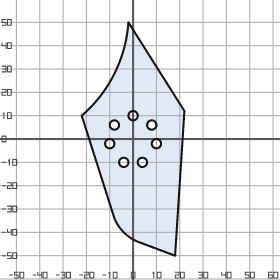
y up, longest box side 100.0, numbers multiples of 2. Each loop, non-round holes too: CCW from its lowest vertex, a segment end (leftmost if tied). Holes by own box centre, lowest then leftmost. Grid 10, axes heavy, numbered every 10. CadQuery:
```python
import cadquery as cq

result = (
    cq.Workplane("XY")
    .moveTo(18.0, -50.0)
    .lineTo(22.0, 12.0)
    .lineTo(-2.0, 50.0)
    .threePointArc((-8.0, 28.0), (-22.0, 10.0))
    .lineTo(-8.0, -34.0)
    .threePointArc((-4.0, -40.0), (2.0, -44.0))
    .close()
    .moveTo(-4.0, -10.0)
    .circle(2.0)
    .moveTo(4.0, -10.0)
    .circle(2.0)
    .moveTo(-10.0, -2.0)
    .circle(2.0)
    .moveTo(10.0, -2.0)
    .circle(2.0)
    .moveTo(-8.0, 6.0)
    .circle(2.0)
    .moveTo(8.0, 6.0)
    .circle(2.0)
    .moveTo(0.0, 10.0)
    .circle(2.0)
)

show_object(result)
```